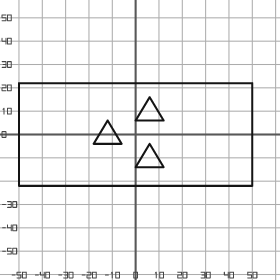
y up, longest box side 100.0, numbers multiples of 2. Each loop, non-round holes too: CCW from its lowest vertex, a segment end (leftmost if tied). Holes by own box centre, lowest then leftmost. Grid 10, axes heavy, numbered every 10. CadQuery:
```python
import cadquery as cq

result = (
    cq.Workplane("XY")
    .moveTo(-50.0, -22.0)
    .lineTo(50.0, -22.0)
    .lineTo(50.0, 22.0)
    .lineTo(-50.0, 22.0)
    .close()
    .moveTo(0.0, -14.0)
    .lineTo(12.0, -14.0)
    .lineTo(6.0, -4.0)
    .close()
    .moveTo(-18.0, -4.0)
    .lineTo(-6.0, -4.0)
    .lineTo(-12.0, 6.0)
    .close()
    .moveTo(0.0, 6.0)
    .lineTo(12.0, 6.0)
    .lineTo(6.0, 16.0)
    .close()
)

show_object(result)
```